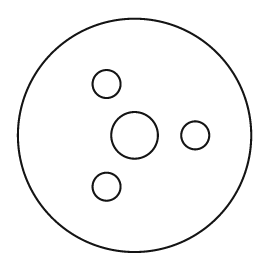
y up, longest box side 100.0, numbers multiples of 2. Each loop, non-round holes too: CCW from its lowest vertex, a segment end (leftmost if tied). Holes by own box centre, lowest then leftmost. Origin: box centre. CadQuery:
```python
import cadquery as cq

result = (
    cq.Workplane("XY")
    .moveTo(0.0, 0.0)
    .circle(50.0)
    .moveTo(-12.0, -22.0)
    .circle(6.0)
    .moveTo(0.0, 0.0)
    .circle(10.0)
    .moveTo(26.0, 0.0)
    .circle(6.0)
    .moveTo(-12.0, 22.0)
    .circle(6.0)
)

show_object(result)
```